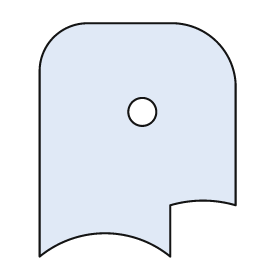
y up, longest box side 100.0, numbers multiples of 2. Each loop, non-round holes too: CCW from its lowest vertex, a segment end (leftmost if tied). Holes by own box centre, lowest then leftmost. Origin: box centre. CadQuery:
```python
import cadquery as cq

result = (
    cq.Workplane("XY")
    .moveTo(-42.0, -50.0)
    .threePointArc((-14.0, -40.0), (14.0, -50.0))
    .lineTo(14.0, -28.0)
    .threePointArc((28.0, -26.0), (42.0, -28.0))
    .lineTo(42.0, 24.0)
    .threePointArc((34.0, 42.0), (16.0, 50.0))
    .lineTo(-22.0, 50.0)
    .threePointArc((-36.0, 44.0), (-42.0, 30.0))
    .close()
    .moveTo(2.0, 12.0)
    .circle(6.0)
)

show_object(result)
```